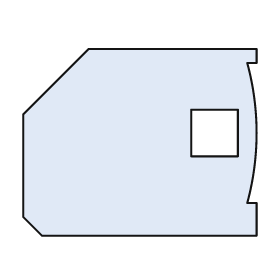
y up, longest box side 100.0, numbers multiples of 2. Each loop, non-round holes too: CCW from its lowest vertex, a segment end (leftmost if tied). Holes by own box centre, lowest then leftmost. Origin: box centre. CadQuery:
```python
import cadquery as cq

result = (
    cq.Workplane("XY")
    .moveTo(-42.0, -40.0)
    .lineTo(50.0, -40.0)
    .lineTo(50.0, -26.0)
    .lineTo(46.0, -26.0)
    .threePointArc((50.0, 4.0), (46.0, 34.0))
    .lineTo(50.0, 34.0)
    .lineTo(50.0, 40.0)
    .lineTo(-22.0, 40.0)
    .lineTo(-50.0, 12.0)
    .lineTo(-50.0, -32.0)
    .close()
    .moveTo(22.0, -6.0)
    .lineTo(42.0, -6.0)
    .lineTo(42.0, 14.0)
    .lineTo(22.0, 14.0)
    .close()
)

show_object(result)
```